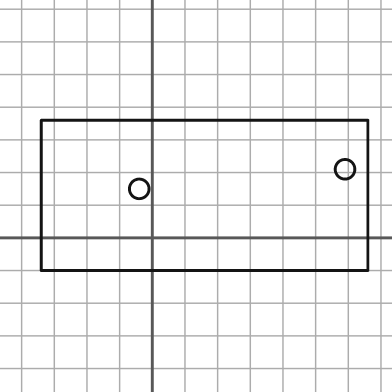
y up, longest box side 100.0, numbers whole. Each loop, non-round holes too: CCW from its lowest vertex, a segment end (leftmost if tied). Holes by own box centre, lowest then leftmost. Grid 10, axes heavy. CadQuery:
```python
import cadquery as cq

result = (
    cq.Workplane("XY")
    .moveTo(-34.0, -10.0)
    .lineTo(66.0, -10.0)
    .lineTo(66.0, 36.0)
    .lineTo(-34.0, 36.0)
    .close()
    .moveTo(-4.0, 15.0)
    .circle(3.0)
    .moveTo(59.0, 21.0)
    .circle(3.0)
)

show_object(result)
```